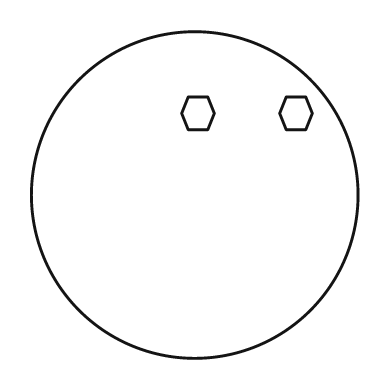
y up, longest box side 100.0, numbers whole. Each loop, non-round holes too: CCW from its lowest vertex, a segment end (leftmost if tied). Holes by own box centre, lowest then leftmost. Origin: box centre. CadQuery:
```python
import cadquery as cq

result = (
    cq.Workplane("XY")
    .moveTo(0.0, 0.0)
    .circle(50.0)
    .moveTo(-2.0, 20.0)
    .lineTo(4.0, 20.0)
    .lineTo(6.0, 25.0)
    .lineTo(4.0, 30.0)
    .lineTo(-2.0, 30.0)
    .lineTo(-4.0, 25.0)
    .close()
    .moveTo(28.0, 20.0)
    .lineTo(34.0, 20.0)
    .lineTo(36.0, 25.0)
    .lineTo(34.0, 30.0)
    .lineTo(28.0, 30.0)
    .lineTo(26.0, 25.0)
    .close()
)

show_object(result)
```